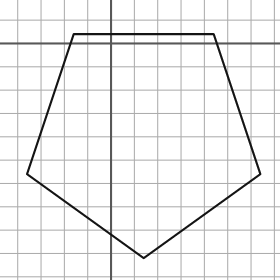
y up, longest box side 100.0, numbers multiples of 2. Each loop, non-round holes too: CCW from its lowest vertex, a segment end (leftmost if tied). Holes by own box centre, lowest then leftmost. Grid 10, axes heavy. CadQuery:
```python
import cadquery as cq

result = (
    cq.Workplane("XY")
    .moveTo(14.0, -92.0)
    .lineTo(64.0, -56.0)
    .lineTo(44.0, 4.0)
    .lineTo(-16.0, 4.0)
    .lineTo(-36.0, -56.0)
    .close()
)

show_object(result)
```